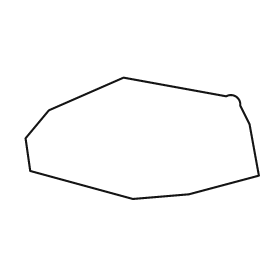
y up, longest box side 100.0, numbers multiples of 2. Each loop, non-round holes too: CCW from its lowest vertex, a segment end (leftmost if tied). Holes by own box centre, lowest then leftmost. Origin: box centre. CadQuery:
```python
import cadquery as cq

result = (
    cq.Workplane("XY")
    .moveTo(-4.0, -26.0)
    .lineTo(20.0, -24.0)
    .lineTo(50.0, -16.0)
    .lineTo(46.0, 6.0)
    .lineTo(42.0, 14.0)
    .threePointArc((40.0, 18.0), (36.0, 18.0))
    .lineTo(-8.0, 26.0)
    .lineTo(-40.0, 12.0)
    .lineTo(-50.0, 0.0)
    .lineTo(-48.0, -14.0)
    .close()
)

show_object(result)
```